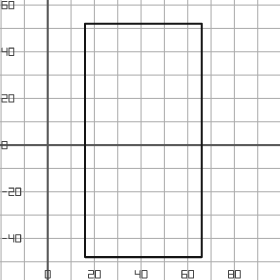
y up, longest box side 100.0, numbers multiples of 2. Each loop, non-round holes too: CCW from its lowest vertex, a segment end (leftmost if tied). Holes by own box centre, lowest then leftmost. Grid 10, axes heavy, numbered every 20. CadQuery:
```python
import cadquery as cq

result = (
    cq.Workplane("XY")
    .moveTo(16.0, -48.0)
    .lineTo(66.0, -48.0)
    .lineTo(66.0, 52.0)
    .lineTo(16.0, 52.0)
    .close()
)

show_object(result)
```